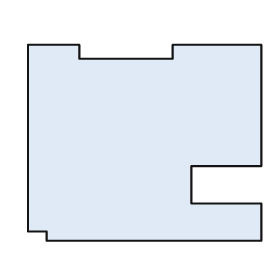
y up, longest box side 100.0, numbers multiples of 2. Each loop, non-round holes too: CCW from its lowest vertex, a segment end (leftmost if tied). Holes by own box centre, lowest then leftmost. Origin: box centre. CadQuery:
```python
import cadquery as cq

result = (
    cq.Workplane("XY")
    .moveTo(-42.0, -42.0)
    .lineTo(50.0, -42.0)
    .lineTo(50.0, -26.0)
    .lineTo(20.0, -26.0)
    .lineTo(20.0, -10.0)
    .lineTo(50.0, -10.0)
    .lineTo(50.0, 42.0)
    .lineTo(12.0, 42.0)
    .lineTo(12.0, 36.0)
    .lineTo(-28.0, 36.0)
    .lineTo(-28.0, 42.0)
    .lineTo(-50.0, 42.0)
    .lineTo(-50.0, -38.0)
    .lineTo(-42.0, -38.0)
    .close()
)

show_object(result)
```